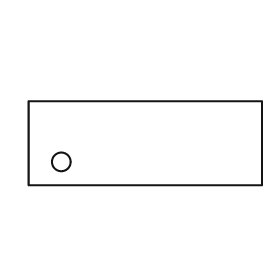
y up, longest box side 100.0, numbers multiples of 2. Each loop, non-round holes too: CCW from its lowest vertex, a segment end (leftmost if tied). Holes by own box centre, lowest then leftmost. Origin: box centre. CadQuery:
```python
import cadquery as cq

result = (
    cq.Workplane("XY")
    .moveTo(-50.0, -18.0)
    .lineTo(50.0, -18.0)
    .lineTo(50.0, 18.0)
    .lineTo(-50.0, 18.0)
    .close()
    .moveTo(-36.0, -8.0)
    .circle(4.0)
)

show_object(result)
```